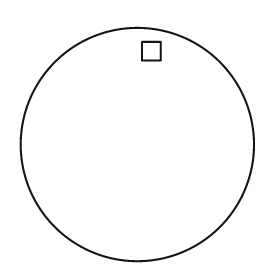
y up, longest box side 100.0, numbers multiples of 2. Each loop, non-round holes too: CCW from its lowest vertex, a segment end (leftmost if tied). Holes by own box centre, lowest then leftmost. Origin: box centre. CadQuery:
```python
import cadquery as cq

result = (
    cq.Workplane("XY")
    .moveTo(0.0, 0.0)
    .circle(50.0)
    .moveTo(2.0, 36.0)
    .lineTo(10.0, 36.0)
    .lineTo(10.0, 44.0)
    .lineTo(2.0, 44.0)
    .close()
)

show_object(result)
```